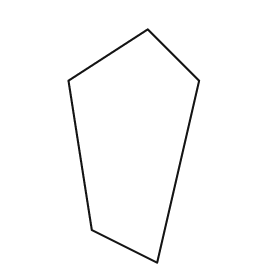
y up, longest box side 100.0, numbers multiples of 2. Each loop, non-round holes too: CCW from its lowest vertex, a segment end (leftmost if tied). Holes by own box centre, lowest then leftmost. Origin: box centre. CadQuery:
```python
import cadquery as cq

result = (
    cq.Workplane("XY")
    .moveTo(10.0, -50.0)
    .lineTo(28.0, 28.0)
    .lineTo(6.0, 50.0)
    .lineTo(-28.0, 28.0)
    .lineTo(-18.0, -36.0)
    .close()
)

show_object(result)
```